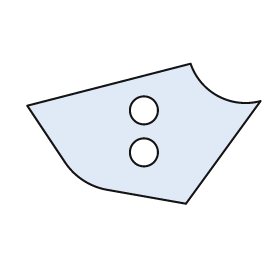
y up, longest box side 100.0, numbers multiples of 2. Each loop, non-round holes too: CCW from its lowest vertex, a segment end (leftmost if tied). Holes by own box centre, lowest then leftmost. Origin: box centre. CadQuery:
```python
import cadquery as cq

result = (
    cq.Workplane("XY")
    .moveTo(18.0, -30.0)
    .lineTo(50.0, 14.0)
    .threePointArc((32.0, 16.0), (20.0, 30.0))
    .lineTo(-50.0, 12.0)
    .lineTo(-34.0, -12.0)
    .threePointArc((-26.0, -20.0), (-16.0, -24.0))
    .close()
    .moveTo(0.0, -8.0)
    .circle(6.0)
    .moveTo(0.0, 10.0)
    .circle(6.0)
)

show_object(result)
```